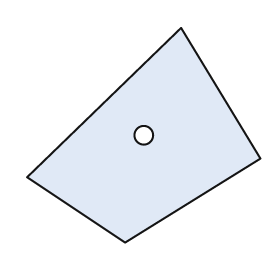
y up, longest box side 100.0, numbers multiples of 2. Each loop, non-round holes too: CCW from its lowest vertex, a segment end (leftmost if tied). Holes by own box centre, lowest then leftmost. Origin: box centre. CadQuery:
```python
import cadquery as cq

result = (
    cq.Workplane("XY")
    .moveTo(-8.0, -46.0)
    .lineTo(50.0, -10.0)
    .lineTo(16.0, 46.0)
    .lineTo(-50.0, -18.0)
    .close()
    .moveTo(0.0, 0.0)
    .circle(4.0)
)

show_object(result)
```